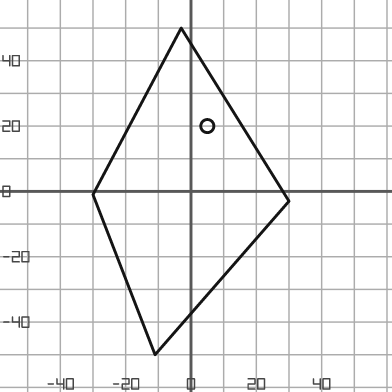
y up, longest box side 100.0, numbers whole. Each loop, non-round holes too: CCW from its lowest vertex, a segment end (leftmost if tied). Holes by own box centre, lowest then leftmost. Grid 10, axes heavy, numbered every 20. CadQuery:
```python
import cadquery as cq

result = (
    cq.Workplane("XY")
    .moveTo(-11.0, -50.0)
    .lineTo(30.0, -3.0)
    .lineTo(-3.0, 50.0)
    .lineTo(-30.0, -1.0)
    .close()
    .moveTo(5.0, 20.0)
    .circle(2.0)
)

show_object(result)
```